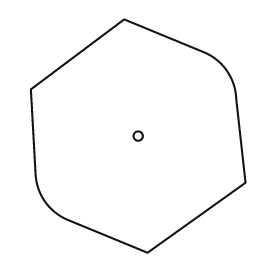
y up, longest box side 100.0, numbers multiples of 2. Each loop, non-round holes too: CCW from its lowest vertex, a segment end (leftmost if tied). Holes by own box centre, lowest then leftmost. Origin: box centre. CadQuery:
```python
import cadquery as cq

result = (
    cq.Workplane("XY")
    .moveTo(4.0, -50.0)
    .lineTo(46.0, -20.0)
    .lineTo(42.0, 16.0)
    .threePointArc((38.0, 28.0), (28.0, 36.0))
    .lineTo(-6.0, 50.0)
    .lineTo(-46.0, 20.0)
    .lineTo(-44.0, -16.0)
    .threePointArc((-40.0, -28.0), (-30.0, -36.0))
    .close()
    .moveTo(0.0, 0.0)
    .circle(2.0)
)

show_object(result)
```